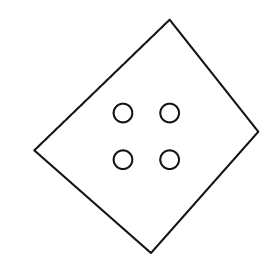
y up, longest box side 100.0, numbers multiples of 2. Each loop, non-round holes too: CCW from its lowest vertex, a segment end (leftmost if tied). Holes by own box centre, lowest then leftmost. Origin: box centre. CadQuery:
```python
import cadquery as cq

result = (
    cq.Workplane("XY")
    .moveTo(2.0, -50.0)
    .lineTo(48.0, 2.0)
    .lineTo(10.0, 50.0)
    .lineTo(-48.0, -6.0)
    .close()
    .moveTo(-10.0, -10.0)
    .circle(4.0)
    .moveTo(10.0, -10.0)
    .circle(4.0)
    .moveTo(-10.0, 10.0)
    .circle(4.0)
    .moveTo(10.0, 10.0)
    .circle(4.0)
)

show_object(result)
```